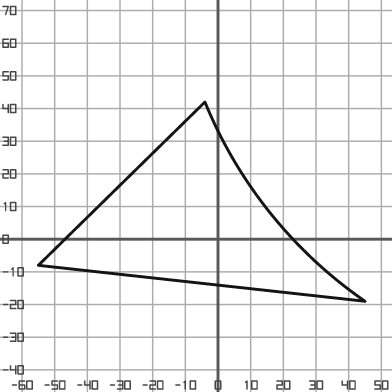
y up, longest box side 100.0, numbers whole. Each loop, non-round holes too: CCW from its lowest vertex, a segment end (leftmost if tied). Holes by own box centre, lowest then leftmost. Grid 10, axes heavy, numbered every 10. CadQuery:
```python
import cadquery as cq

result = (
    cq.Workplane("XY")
    .moveTo(45.0, -19.0)
    .threePointArc((16.0, 8.0), (-4.0, 42.0))
    .lineTo(-55.0, -8.0)
    .close()
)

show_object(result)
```